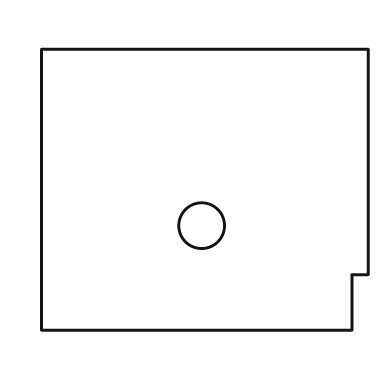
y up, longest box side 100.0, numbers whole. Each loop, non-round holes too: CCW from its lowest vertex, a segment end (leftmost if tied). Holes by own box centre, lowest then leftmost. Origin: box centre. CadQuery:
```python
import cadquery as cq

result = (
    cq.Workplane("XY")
    .moveTo(-50.0, -43.0)
    .lineTo(45.0, -43.0)
    .lineTo(45.0, -26.0)
    .lineTo(50.0, -26.0)
    .lineTo(50.0, 43.0)
    .lineTo(-50.0, 43.0)
    .close()
    .moveTo(-1.0, -11.0)
    .circle(7.0)
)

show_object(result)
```